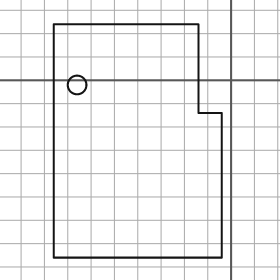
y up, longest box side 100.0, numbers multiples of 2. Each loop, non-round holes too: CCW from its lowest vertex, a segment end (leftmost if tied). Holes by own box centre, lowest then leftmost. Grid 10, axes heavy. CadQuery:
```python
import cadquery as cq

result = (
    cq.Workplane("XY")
    .moveTo(-76.0, -76.0)
    .lineTo(-4.0, -76.0)
    .lineTo(-4.0, -14.0)
    .lineTo(-14.0, -14.0)
    .lineTo(-14.0, 24.0)
    .lineTo(-76.0, 24.0)
    .close()
    .moveTo(-66.0, -2.0)
    .circle(4.0)
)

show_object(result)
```